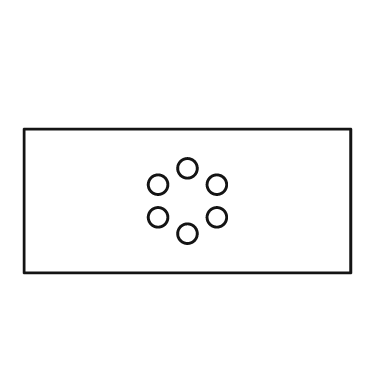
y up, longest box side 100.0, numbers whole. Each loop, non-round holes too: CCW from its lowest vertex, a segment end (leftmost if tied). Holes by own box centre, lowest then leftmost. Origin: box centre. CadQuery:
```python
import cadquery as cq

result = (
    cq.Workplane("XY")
    .moveTo(-50.0, -22.0)
    .lineTo(50.0, -22.0)
    .lineTo(50.0, 22.0)
    .lineTo(-50.0, 22.0)
    .close()
    .moveTo(0.0, -10.0)
    .circle(3.0)
    .moveTo(-9.0, -5.0)
    .circle(3.0)
    .moveTo(9.0, -5.0)
    .circle(3.0)
    .moveTo(-9.0, 5.0)
    .circle(3.0)
    .moveTo(9.0, 5.0)
    .circle(3.0)
    .moveTo(0.0, 10.0)
    .circle(3.0)
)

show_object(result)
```